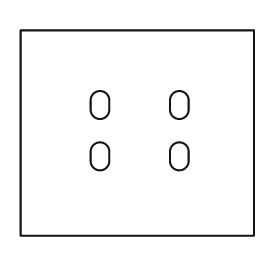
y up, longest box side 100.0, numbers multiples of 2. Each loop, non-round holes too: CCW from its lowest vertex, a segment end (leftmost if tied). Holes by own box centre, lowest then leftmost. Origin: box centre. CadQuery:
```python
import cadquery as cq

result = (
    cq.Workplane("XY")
    .moveTo(-50.0, -44.0)
    .lineTo(50.0, -44.0)
    .lineTo(50.0, 44.0)
    .lineTo(-50.0, 44.0)
    .close()
    .moveTo(-20.0, -12.0)
    .threePointArc((-16.0, -16.0), (-12.0, -12.0))
    .lineTo(-12.0, -8.0)
    .threePointArc((-16.0, -4.0), (-20.0, -8.0))
    .close()
    .moveTo(14.0, -12.0)
    .threePointArc((18.0, -16.0), (22.0, -12.0))
    .lineTo(22.0, -8.0)
    .threePointArc((18.0, -4.0), (14.0, -8.0))
    .close()
    .moveTo(-20.0, 10.0)
    .threePointArc((-16.0, 6.0), (-12.0, 10.0))
    .lineTo(-12.0, 14.0)
    .threePointArc((-16.0, 18.0), (-20.0, 14.0))
    .close()
    .moveTo(14.0, 10.0)
    .threePointArc((18.0, 6.0), (22.0, 10.0))
    .lineTo(22.0, 14.0)
    .threePointArc((18.0, 18.0), (14.0, 14.0))
    .close()
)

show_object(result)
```